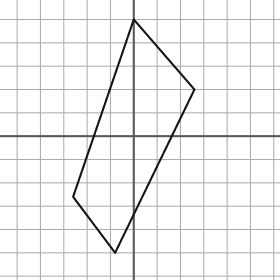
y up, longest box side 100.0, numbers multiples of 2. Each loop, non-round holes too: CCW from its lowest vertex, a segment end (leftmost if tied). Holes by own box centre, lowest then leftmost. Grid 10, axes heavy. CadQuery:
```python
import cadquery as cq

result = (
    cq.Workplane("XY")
    .moveTo(-8.0, -50.0)
    .lineTo(26.0, 20.0)
    .lineTo(0.0, 50.0)
    .lineTo(-26.0, -26.0)
    .close()
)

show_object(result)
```